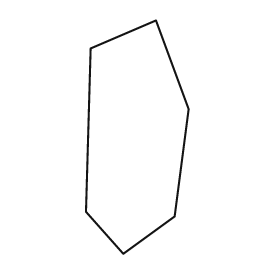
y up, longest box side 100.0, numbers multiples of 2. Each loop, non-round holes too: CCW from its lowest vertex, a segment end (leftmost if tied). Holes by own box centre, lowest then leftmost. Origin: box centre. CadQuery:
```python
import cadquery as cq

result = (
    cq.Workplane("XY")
    .moveTo(-6.0, -50.0)
    .lineTo(16.0, -34.0)
    .lineTo(22.0, 12.0)
    .lineTo(8.0, 50.0)
    .lineTo(-20.0, 38.0)
    .lineTo(-22.0, -32.0)
    .close()
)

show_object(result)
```